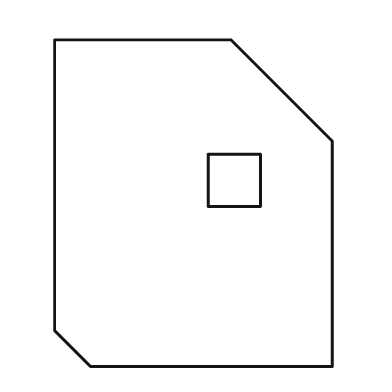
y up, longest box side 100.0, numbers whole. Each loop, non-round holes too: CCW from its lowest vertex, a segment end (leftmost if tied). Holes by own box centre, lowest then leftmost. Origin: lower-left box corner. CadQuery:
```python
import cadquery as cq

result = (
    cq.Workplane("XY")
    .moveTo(11.0, 0.0)
    .lineTo(85.0, 0.0)
    .lineTo(85.0, 69.0)
    .lineTo(54.0, 100.0)
    .lineTo(0.0, 100.0)
    .lineTo(0.0, 11.0)
    .close()
    .moveTo(47.0, 49.0)
    .lineTo(63.0, 49.0)
    .lineTo(63.0, 65.0)
    .lineTo(47.0, 65.0)
    .close()
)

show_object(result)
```